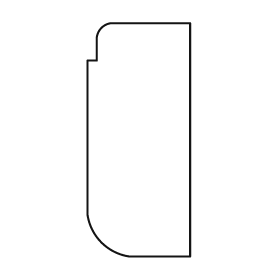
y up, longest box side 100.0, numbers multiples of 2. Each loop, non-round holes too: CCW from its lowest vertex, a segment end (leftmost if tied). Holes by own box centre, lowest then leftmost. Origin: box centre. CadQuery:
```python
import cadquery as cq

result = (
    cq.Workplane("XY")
    .moveTo(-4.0, -50.0)
    .lineTo(22.0, -50.0)
    .lineTo(22.0, 50.0)
    .lineTo(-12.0, 50.0)
    .threePointArc((-16.0, 48.0), (-18.0, 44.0))
    .lineTo(-18.0, 34.0)
    .lineTo(-22.0, 34.0)
    .lineTo(-22.0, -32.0)
    .threePointArc((-16.0, -44.0), (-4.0, -50.0))
    .close()
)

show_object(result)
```